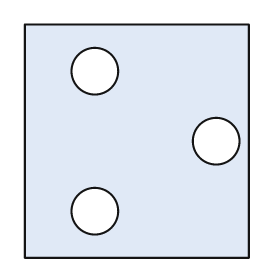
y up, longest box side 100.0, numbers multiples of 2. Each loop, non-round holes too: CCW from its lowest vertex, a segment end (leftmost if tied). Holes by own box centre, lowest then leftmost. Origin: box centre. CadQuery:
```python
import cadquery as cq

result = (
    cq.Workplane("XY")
    .moveTo(-48.0, -50.0)
    .lineTo(48.0, -50.0)
    .lineTo(48.0, 50.0)
    .lineTo(-48.0, 50.0)
    .close()
    .moveTo(-18.0, -30.0)
    .circle(10.0)
    .moveTo(34.0, 0.0)
    .circle(10.0)
    .moveTo(-18.0, 30.0)
    .circle(10.0)
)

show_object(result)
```